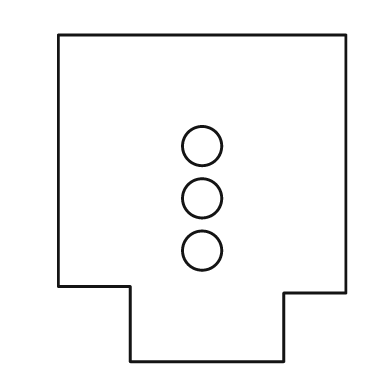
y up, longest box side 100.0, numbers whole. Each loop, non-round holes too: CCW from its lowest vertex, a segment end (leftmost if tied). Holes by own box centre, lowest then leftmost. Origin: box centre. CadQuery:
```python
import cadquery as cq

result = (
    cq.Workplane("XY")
    .moveTo(-22.0, -50.0)
    .lineTo(25.0, -50.0)
    .lineTo(25.0, -29.0)
    .lineTo(44.0, -29.0)
    .lineTo(44.0, 50.0)
    .lineTo(-44.0, 50.0)
    .lineTo(-44.0, -27.0)
    .lineTo(-22.0, -27.0)
    .close()
    .moveTo(0.0, -16.0)
    .circle(6.0)
    .moveTo(0.0, 0.0)
    .circle(6.0)
    .moveTo(0.0, 16.0)
    .circle(6.0)
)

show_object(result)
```